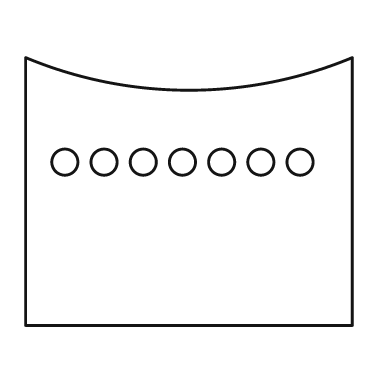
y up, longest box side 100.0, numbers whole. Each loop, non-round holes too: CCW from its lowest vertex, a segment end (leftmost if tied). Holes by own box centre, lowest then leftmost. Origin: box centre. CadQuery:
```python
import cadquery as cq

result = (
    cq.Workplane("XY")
    .moveTo(-50.0, -41.0)
    .lineTo(50.0, -41.0)
    .lineTo(50.0, 41.0)
    .threePointArc((0.0, 31.0), (-50.0, 41.0))
    .close()
    .moveTo(-38.0, 9.0)
    .circle(4.0)
    .moveTo(-26.0, 9.0)
    .circle(4.0)
    .moveTo(-14.0, 9.0)
    .circle(4.0)
    .moveTo(-2.0, 9.0)
    .circle(4.0)
    .moveTo(10.0, 9.0)
    .circle(4.0)
    .moveTo(22.0, 9.0)
    .circle(4.0)
    .moveTo(34.0, 9.0)
    .circle(4.0)
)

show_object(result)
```